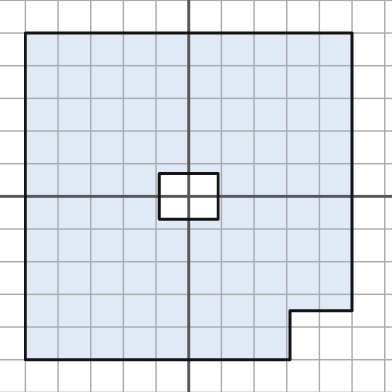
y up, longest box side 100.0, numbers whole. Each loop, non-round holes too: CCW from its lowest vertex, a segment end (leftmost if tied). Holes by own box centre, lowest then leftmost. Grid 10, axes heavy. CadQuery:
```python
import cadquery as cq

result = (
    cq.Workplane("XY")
    .moveTo(-50.0, -50.0)
    .lineTo(31.0, -50.0)
    .lineTo(31.0, -35.0)
    .lineTo(50.0, -35.0)
    .lineTo(50.0, 50.0)
    .lineTo(-50.0, 50.0)
    .close()
    .moveTo(-9.0, -7.0)
    .lineTo(9.0, -7.0)
    .lineTo(9.0, 7.0)
    .lineTo(-9.0, 7.0)
    .close()
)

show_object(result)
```